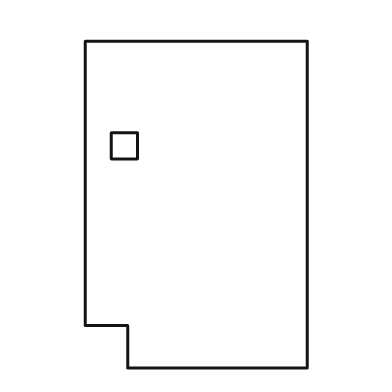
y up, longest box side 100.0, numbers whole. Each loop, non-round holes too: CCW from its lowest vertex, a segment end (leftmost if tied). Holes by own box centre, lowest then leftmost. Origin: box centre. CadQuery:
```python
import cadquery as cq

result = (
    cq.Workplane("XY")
    .moveTo(-21.0, -50.0)
    .lineTo(34.0, -50.0)
    .lineTo(34.0, 50.0)
    .lineTo(-34.0, 50.0)
    .lineTo(-34.0, -37.0)
    .lineTo(-21.0, -37.0)
    .close()
    .moveTo(-26.0, 14.0)
    .lineTo(-18.0, 14.0)
    .lineTo(-18.0, 22.0)
    .lineTo(-26.0, 22.0)
    .close()
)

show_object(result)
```